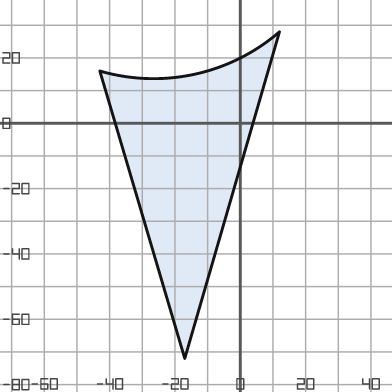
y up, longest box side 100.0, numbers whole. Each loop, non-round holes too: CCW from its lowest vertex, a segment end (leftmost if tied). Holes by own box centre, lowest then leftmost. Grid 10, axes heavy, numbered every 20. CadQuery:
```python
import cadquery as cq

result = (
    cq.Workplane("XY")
    .moveTo(-17.0, -72.0)
    .lineTo(12.0, 28.0)
    .threePointArc((-14.0, 15.0), (-43.0, 16.0))
    .close()
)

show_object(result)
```